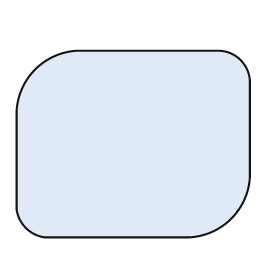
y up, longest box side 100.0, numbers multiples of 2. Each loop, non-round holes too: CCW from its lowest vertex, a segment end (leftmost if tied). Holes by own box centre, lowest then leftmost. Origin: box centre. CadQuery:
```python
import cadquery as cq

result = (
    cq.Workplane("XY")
    .moveTo(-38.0, -40.0)
    .lineTo(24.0, -40.0)
    .threePointArc((42.0, -32.0), (50.0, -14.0))
    .lineTo(50.0, 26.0)
    .threePointArc((46.0, 36.0), (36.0, 40.0))
    .lineTo(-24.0, 40.0)
    .threePointArc((-42.0, 32.0), (-50.0, 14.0))
    .lineTo(-50.0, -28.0)
    .threePointArc((-46.0, -36.0), (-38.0, -40.0))
    .close()
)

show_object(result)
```